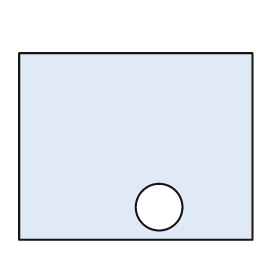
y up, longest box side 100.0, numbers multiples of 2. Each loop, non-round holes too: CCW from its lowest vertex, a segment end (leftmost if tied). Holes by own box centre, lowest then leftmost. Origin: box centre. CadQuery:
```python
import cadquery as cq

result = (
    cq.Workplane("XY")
    .moveTo(-50.0, -40.0)
    .lineTo(50.0, -40.0)
    .lineTo(50.0, 40.0)
    .lineTo(-50.0, 40.0)
    .close()
    .moveTo(10.0, -26.0)
    .circle(10.0)
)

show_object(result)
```